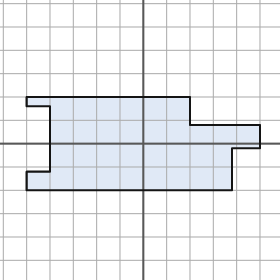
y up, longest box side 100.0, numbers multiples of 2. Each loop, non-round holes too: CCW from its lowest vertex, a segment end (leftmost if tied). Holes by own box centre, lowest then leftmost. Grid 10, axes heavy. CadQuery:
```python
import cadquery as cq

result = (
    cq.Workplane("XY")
    .moveTo(-50.0, -20.0)
    .lineTo(38.0, -20.0)
    .lineTo(38.0, -2.0)
    .lineTo(50.0, -2.0)
    .lineTo(50.0, 8.0)
    .lineTo(20.0, 8.0)
    .lineTo(20.0, 20.0)
    .lineTo(-50.0, 20.0)
    .lineTo(-50.0, 16.0)
    .lineTo(-40.0, 16.0)
    .lineTo(-40.0, -12.0)
    .lineTo(-50.0, -12.0)
    .close()
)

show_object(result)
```